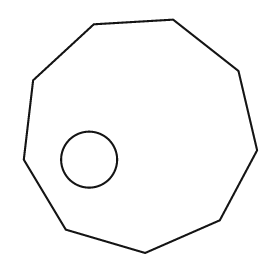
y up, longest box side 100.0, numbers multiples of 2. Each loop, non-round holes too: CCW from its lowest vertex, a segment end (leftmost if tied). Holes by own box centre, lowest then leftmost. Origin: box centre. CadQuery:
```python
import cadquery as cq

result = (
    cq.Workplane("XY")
    .moveTo(2.0, -50.0)
    .lineTo(34.0, -36.0)
    .lineTo(50.0, -6.0)
    .lineTo(42.0, 28.0)
    .lineTo(14.0, 50.0)
    .lineTo(-20.0, 48.0)
    .lineTo(-46.0, 24.0)
    .lineTo(-50.0, -10.0)
    .lineTo(-32.0, -40.0)
    .close()
    .moveTo(-22.0, -10.0)
    .circle(12.0)
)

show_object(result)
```